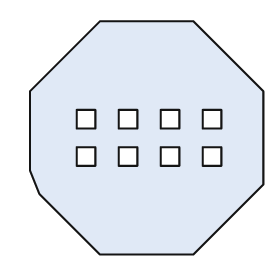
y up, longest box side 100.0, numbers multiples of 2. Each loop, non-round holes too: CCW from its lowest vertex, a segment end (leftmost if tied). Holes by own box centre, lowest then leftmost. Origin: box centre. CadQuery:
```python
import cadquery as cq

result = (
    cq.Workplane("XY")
    .moveTo(-20.0, -50.0)
    .lineTo(20.0, -50.0)
    .lineTo(50.0, -20.0)
    .lineTo(50.0, 20.0)
    .lineTo(20.0, 50.0)
    .lineTo(-20.0, 50.0)
    .lineTo(-50.0, 20.0)
    .lineTo(-50.0, -14.0)
    .lineTo(-46.0, -24.0)
    .close()
    .moveTo(-30.0, -12.0)
    .lineTo(-22.0, -12.0)
    .lineTo(-22.0, -4.0)
    .lineTo(-30.0, -4.0)
    .close()
    .moveTo(-12.0, -12.0)
    .lineTo(-4.0, -12.0)
    .lineTo(-4.0, -4.0)
    .lineTo(-12.0, -4.0)
    .close()
    .moveTo(6.0, -12.0)
    .lineTo(14.0, -12.0)
    .lineTo(14.0, -4.0)
    .lineTo(6.0, -4.0)
    .close()
    .moveTo(24.0, -12.0)
    .lineTo(32.0, -12.0)
    .lineTo(32.0, -4.0)
    .lineTo(24.0, -4.0)
    .close()
    .moveTo(-30.0, 4.0)
    .lineTo(-22.0, 4.0)
    .lineTo(-22.0, 12.0)
    .lineTo(-30.0, 12.0)
    .close()
    .moveTo(-12.0, 4.0)
    .lineTo(-4.0, 4.0)
    .lineTo(-4.0, 12.0)
    .lineTo(-12.0, 12.0)
    .close()
    .moveTo(6.0, 4.0)
    .lineTo(14.0, 4.0)
    .lineTo(14.0, 12.0)
    .lineTo(6.0, 12.0)
    .close()
    .moveTo(24.0, 4.0)
    .lineTo(32.0, 4.0)
    .lineTo(32.0, 12.0)
    .lineTo(24.0, 12.0)
    .close()
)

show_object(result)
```